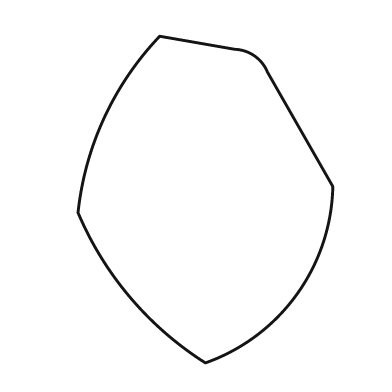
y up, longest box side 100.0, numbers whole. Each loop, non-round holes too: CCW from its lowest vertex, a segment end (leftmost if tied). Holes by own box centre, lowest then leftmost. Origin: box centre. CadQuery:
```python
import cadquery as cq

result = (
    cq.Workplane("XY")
    .moveTo(0.0, -50.0)
    .threePointArc((28.0, -29.0), (39.0, 4.0))
    .lineTo(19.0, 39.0)
    .threePointArc((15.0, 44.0), (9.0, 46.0))
    .lineTo(-14.0, 50.0)
    .threePointArc((-31.0, 25.0), (-39.0, -4.0))
    .threePointArc((-23.0, -30.0), (0.0, -50.0))
    .close()
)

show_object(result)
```